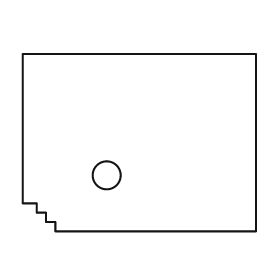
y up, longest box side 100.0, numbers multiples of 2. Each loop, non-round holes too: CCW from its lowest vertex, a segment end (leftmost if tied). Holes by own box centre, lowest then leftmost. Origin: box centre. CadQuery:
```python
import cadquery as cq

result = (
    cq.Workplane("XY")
    .moveTo(-36.0, -38.0)
    .lineTo(50.0, -38.0)
    .lineTo(50.0, 38.0)
    .lineTo(-50.0, 38.0)
    .lineTo(-50.0, -26.0)
    .lineTo(-44.0, -26.0)
    .lineTo(-44.0, -30.0)
    .lineTo(-40.0, -30.0)
    .lineTo(-40.0, -34.0)
    .lineTo(-36.0, -34.0)
    .close()
    .moveTo(-14.0, -14.0)
    .circle(6.0)
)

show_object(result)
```